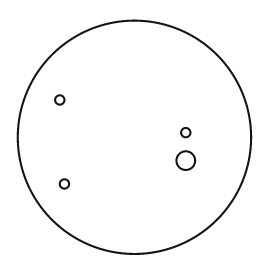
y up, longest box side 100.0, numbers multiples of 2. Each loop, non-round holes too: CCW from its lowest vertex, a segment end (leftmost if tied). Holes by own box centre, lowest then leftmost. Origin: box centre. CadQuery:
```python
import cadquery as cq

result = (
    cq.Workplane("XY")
    .moveTo(0.0, 0.0)
    .circle(50.0)
    .moveTo(-30.0, -20.0)
    .circle(2.0)
    .moveTo(22.0, -10.0)
    .circle(4.0)
    .moveTo(22.0, 2.0)
    .circle(2.0)
    .moveTo(-32.0, 16.0)
    .circle(2.0)
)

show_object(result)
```